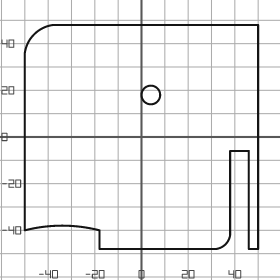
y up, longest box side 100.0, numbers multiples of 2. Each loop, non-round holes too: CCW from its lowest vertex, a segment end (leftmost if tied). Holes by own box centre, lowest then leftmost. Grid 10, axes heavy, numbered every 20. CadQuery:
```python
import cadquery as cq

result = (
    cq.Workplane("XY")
    .moveTo(-18.0, -48.0)
    .lineTo(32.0, -48.0)
    .threePointArc((36.0, -46.0), (38.0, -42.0))
    .lineTo(38.0, -6.0)
    .lineTo(46.0, -6.0)
    .lineTo(46.0, -48.0)
    .lineTo(50.0, -48.0)
    .lineTo(50.0, 48.0)
    .lineTo(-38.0, 48.0)
    .threePointArc((-46.0, 44.0), (-50.0, 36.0))
    .lineTo(-50.0, -40.0)
    .threePointArc((-34.0, -38.0), (-18.0, -40.0))
    .close()
    .moveTo(4.0, 18.0)
    .circle(4.0)
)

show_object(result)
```